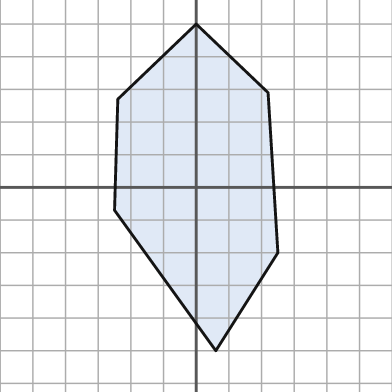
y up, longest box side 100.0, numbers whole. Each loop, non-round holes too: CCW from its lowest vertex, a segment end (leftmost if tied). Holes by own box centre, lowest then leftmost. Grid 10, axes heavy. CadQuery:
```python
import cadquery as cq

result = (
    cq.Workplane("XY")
    .moveTo(6.0, -50.0)
    .lineTo(25.0, -20.0)
    .lineTo(22.0, 29.0)
    .lineTo(0.0, 50.0)
    .lineTo(-24.0, 27.0)
    .lineTo(-25.0, -7.0)
    .close()
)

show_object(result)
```